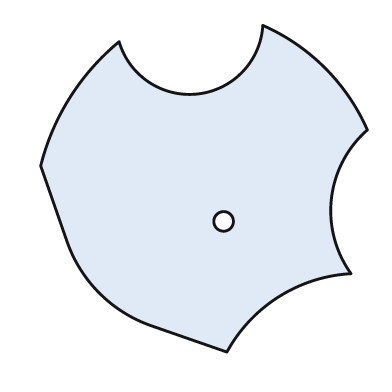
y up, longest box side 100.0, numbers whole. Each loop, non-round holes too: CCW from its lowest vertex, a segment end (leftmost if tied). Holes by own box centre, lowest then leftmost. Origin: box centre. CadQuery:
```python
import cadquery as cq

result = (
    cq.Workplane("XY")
    .moveTo(7.0, -50.0)
    .threePointArc((23.0, -33.0), (45.0, -26.0))
    .threePointArc((39.0, -3.0), (50.0, 18.0))
    .threePointArc((37.0, 37.0), (18.0, 50.0))
    .threePointArc((-2.0, 29.0), (-26.0, 45.0))
    .threePointArc((-41.0, 28.0), (-50.0, 7.0))
    .lineTo(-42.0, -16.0)
    .threePointArc((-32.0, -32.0), (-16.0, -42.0))
    .close()
    .moveTo(6.0, -10.0)
    .circle(3.0)
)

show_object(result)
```